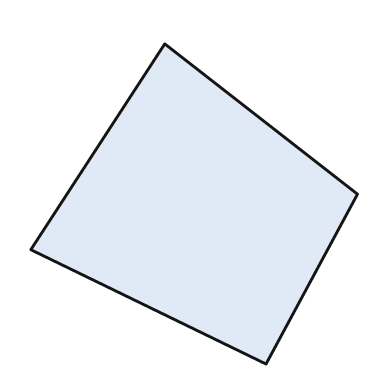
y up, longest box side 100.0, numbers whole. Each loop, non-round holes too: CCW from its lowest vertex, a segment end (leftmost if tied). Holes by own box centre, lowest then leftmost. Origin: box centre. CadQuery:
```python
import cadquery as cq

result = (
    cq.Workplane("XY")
    .moveTo(22.0, -49.0)
    .lineTo(50.0, 3.0)
    .lineTo(-9.0, 49.0)
    .lineTo(-50.0, -14.0)
    .close()
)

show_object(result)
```